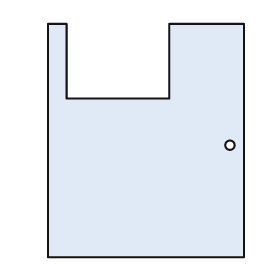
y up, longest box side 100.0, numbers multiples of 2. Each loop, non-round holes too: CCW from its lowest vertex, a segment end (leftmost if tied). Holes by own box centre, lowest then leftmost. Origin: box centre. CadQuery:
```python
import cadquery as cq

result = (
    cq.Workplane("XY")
    .moveTo(-42.0, -50.0)
    .lineTo(42.0, -50.0)
    .lineTo(42.0, 50.0)
    .lineTo(10.0, 50.0)
    .lineTo(10.0, 18.0)
    .lineTo(-34.0, 18.0)
    .lineTo(-34.0, 50.0)
    .lineTo(-42.0, 50.0)
    .close()
    .moveTo(36.0, -2.0)
    .circle(2.0)
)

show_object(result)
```